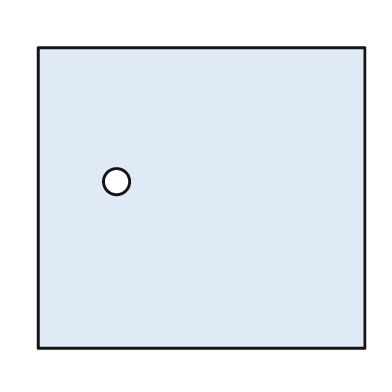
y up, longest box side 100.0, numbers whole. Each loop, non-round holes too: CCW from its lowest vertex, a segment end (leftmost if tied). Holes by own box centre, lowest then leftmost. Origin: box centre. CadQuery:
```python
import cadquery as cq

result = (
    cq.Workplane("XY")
    .moveTo(-50.0, -46.0)
    .lineTo(50.0, -46.0)
    .lineTo(50.0, 46.0)
    .lineTo(-50.0, 46.0)
    .close()
    .moveTo(-26.0, 5.0)
    .circle(4.0)
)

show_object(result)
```